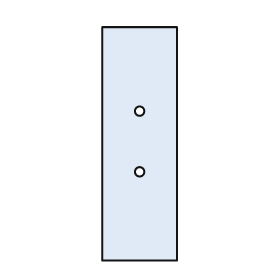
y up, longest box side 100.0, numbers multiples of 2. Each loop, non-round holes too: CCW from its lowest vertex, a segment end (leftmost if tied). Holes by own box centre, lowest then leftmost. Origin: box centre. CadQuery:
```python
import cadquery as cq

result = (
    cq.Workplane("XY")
    .moveTo(-16.0, -50.0)
    .lineTo(16.0, -50.0)
    .lineTo(16.0, 50.0)
    .lineTo(-16.0, 50.0)
    .close()
    .moveTo(0.0, -12.0)
    .circle(2.0)
    .moveTo(0.0, 14.0)
    .circle(2.0)
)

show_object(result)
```